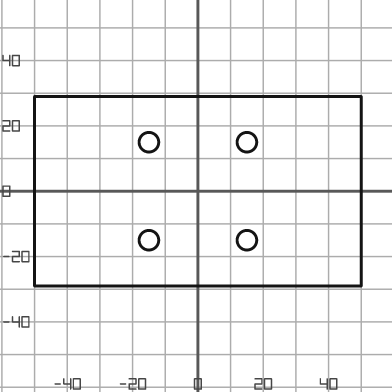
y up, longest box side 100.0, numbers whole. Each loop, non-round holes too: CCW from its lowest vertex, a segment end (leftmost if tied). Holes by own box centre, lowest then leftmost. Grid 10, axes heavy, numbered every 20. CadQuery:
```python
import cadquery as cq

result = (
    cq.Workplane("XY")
    .moveTo(-50.0, -29.0)
    .lineTo(50.0, -29.0)
    .lineTo(50.0, 29.0)
    .lineTo(-50.0, 29.0)
    .close()
    .moveTo(-15.0, -15.0)
    .circle(3.0)
    .moveTo(15.0, -15.0)
    .circle(3.0)
    .moveTo(-15.0, 15.0)
    .circle(3.0)
    .moveTo(15.0, 15.0)
    .circle(3.0)
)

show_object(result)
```